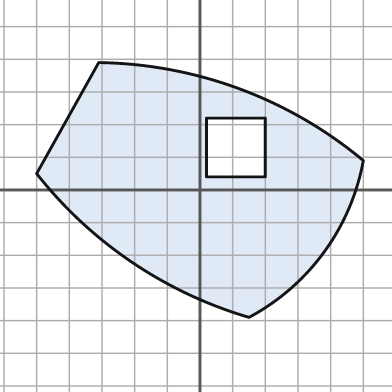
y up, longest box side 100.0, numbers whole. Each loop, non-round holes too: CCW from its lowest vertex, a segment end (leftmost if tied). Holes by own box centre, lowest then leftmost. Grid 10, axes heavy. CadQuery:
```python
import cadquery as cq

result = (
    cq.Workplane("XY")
    .moveTo(15.0, -39.0)
    .threePointArc((38.0, -19.0), (50.0, 9.0))
    .threePointArc((12.0, 31.0), (-31.0, 39.0))
    .lineTo(-50.0, 5.0)
    .threePointArc((-21.0, -22.0), (15.0, -39.0))
    .close()
    .moveTo(2.0, 4.0)
    .lineTo(20.0, 4.0)
    .lineTo(20.0, 22.0)
    .lineTo(2.0, 22.0)
    .close()
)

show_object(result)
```